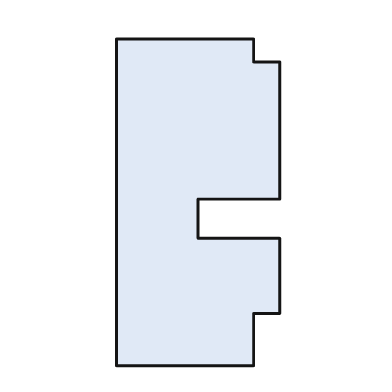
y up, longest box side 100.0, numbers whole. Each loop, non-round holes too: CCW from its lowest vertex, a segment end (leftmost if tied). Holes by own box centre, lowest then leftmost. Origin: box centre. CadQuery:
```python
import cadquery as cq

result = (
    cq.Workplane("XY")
    .moveTo(-25.0, -50.0)
    .lineTo(17.0, -50.0)
    .lineTo(17.0, -34.0)
    .lineTo(25.0, -34.0)
    .lineTo(25.0, -11.0)
    .lineTo(0.0, -11.0)
    .lineTo(0.0, 1.0)
    .lineTo(25.0, 1.0)
    .lineTo(25.0, 43.0)
    .lineTo(17.0, 43.0)
    .lineTo(17.0, 50.0)
    .lineTo(-25.0, 50.0)
    .close()
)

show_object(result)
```